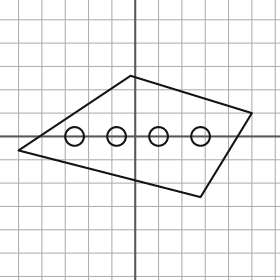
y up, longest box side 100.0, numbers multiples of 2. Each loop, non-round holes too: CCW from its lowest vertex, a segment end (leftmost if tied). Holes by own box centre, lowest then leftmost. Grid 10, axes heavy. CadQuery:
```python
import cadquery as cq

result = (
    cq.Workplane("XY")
    .moveTo(28.0, -26.0)
    .lineTo(50.0, 10.0)
    .lineTo(-2.0, 26.0)
    .lineTo(-50.0, -6.0)
    .close()
    .moveTo(-26.0, 0.0)
    .circle(4.0)
    .moveTo(-8.0, 0.0)
    .circle(4.0)
    .moveTo(10.0, 0.0)
    .circle(4.0)
    .moveTo(28.0, 0.0)
    .circle(4.0)
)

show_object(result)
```